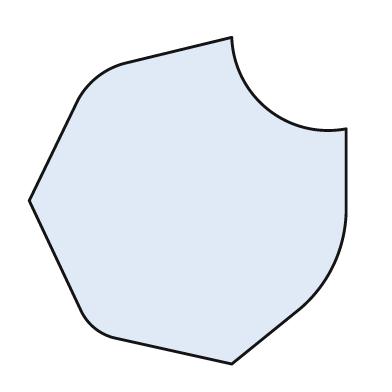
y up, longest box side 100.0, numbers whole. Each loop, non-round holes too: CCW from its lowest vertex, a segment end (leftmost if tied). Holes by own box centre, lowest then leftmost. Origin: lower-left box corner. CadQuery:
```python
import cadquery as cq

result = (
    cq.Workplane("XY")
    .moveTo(62.0, 0.0)
    .lineTo(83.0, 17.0)
    .threePointArc((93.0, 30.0), (97.0, 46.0))
    .lineTo(97.0, 72.0)
    .threePointArc((73.0, 78.0), (62.0, 100.0))
    .lineTo(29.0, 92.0)
    .threePointArc((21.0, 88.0), (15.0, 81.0))
    .lineTo(0.0, 50.0)
    .lineTo(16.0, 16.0)
    .threePointArc((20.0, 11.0), (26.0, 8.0))
    .close()
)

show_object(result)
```